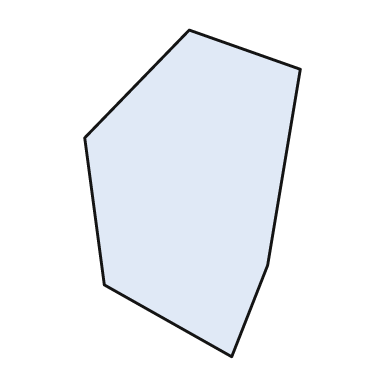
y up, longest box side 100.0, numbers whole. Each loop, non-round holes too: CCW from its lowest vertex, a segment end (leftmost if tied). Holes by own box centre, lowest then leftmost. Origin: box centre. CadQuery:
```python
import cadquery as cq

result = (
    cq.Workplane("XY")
    .moveTo(12.0, -50.0)
    .lineTo(23.0, -22.0)
    .lineTo(33.0, 38.0)
    .lineTo(-1.0, 50.0)
    .lineTo(-33.0, 17.0)
    .lineTo(-27.0, -28.0)
    .close()
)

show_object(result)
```